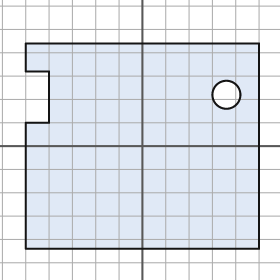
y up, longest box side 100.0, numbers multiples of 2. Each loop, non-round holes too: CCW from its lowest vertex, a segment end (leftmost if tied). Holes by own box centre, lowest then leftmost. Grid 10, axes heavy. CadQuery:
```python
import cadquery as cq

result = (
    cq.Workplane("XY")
    .moveTo(-50.0, -44.0)
    .lineTo(50.0, -44.0)
    .lineTo(50.0, 44.0)
    .lineTo(-50.0, 44.0)
    .lineTo(-50.0, 32.0)
    .lineTo(-40.0, 32.0)
    .lineTo(-40.0, 10.0)
    .lineTo(-50.0, 10.0)
    .close()
    .moveTo(36.0, 22.0)
    .circle(6.0)
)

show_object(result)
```